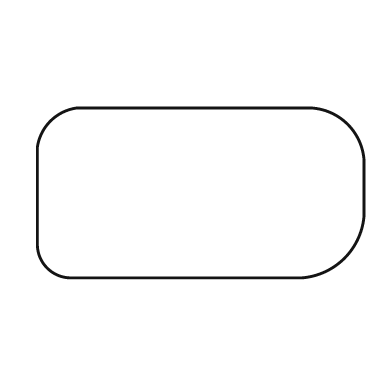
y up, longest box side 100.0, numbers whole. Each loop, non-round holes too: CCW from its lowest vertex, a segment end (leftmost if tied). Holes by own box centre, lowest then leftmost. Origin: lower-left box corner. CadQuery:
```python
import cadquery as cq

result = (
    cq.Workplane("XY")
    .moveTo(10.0, 0.0)
    .lineTo(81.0, 0.0)
    .threePointArc((94.0, 6.0), (100.0, 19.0))
    .lineTo(100.0, 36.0)
    .threePointArc((95.0, 47.0), (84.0, 52.0))
    .lineTo(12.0, 52.0)
    .threePointArc((4.0, 48.0), (0.0, 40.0))
    .lineTo(0.0, 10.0)
    .threePointArc((3.0, 3.0), (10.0, 0.0))
    .close()
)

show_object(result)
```